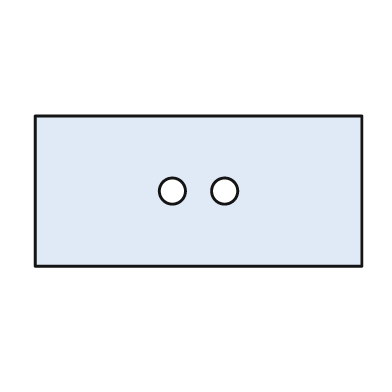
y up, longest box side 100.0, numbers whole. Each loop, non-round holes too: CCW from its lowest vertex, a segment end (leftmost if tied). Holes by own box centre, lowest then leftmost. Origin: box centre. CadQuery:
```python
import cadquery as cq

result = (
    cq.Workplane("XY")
    .moveTo(-50.0, -23.0)
    .lineTo(50.0, -23.0)
    .lineTo(50.0, 23.0)
    .lineTo(-50.0, 23.0)
    .close()
    .moveTo(-8.0, 0.0)
    .circle(4.0)
    .moveTo(8.0, 0.0)
    .circle(4.0)
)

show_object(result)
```